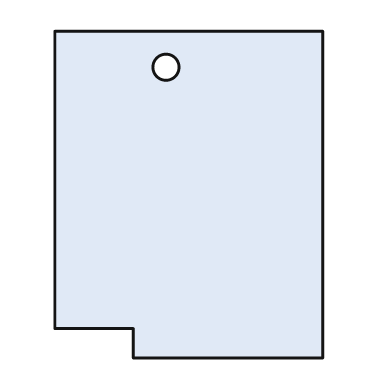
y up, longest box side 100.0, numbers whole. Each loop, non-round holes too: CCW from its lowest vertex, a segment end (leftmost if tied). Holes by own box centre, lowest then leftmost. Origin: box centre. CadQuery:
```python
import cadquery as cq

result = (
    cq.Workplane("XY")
    .moveTo(-17.0, -50.0)
    .lineTo(41.0, -50.0)
    .lineTo(41.0, 50.0)
    .lineTo(-41.0, 50.0)
    .lineTo(-41.0, -41.0)
    .lineTo(-17.0, -41.0)
    .close()
    .moveTo(-7.0, 39.0)
    .circle(4.0)
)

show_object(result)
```